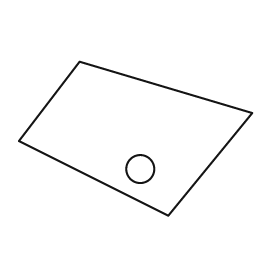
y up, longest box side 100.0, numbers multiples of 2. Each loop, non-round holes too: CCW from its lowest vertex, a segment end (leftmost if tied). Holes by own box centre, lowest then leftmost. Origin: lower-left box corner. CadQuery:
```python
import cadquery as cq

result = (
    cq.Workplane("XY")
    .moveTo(64.0, 0.0)
    .lineTo(100.0, 44.0)
    .lineTo(26.0, 66.0)
    .lineTo(0.0, 32.0)
    .close()
    .moveTo(52.0, 20.0)
    .circle(6.0)
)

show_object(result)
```